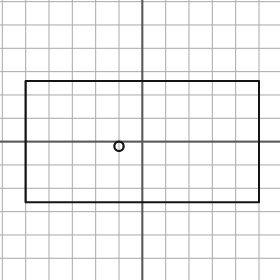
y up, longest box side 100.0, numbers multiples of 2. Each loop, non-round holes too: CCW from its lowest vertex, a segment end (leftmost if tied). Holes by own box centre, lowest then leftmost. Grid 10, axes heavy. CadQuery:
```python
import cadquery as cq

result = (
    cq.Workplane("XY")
    .moveTo(-50.0, -26.0)
    .lineTo(50.0, -26.0)
    .lineTo(50.0, 26.0)
    .lineTo(-50.0, 26.0)
    .close()
    .moveTo(-10.0, -2.0)
    .circle(2.0)
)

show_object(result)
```